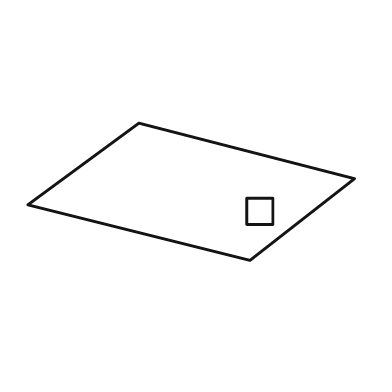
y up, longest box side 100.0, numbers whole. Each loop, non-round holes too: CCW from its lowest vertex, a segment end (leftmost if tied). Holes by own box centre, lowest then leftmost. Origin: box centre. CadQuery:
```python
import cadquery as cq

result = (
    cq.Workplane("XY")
    .moveTo(18.0, -21.0)
    .lineTo(50.0, 4.0)
    .lineTo(-16.0, 21.0)
    .lineTo(-50.0, -4.0)
    .close()
    .moveTo(17.0, -10.0)
    .lineTo(25.0, -10.0)
    .lineTo(25.0, -2.0)
    .lineTo(17.0, -2.0)
    .close()
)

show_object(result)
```